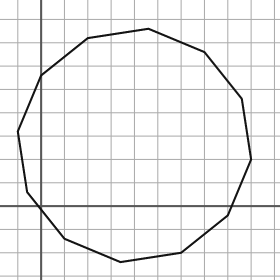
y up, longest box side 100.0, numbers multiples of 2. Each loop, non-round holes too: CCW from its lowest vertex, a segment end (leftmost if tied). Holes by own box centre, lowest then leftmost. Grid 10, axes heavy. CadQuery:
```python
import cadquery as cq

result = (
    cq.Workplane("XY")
    .moveTo(34.0, -24.0)
    .lineTo(60.0, -20.0)
    .lineTo(80.0, -4.0)
    .lineTo(90.0, 20.0)
    .lineTo(86.0, 46.0)
    .lineTo(70.0, 66.0)
    .lineTo(46.0, 76.0)
    .lineTo(20.0, 72.0)
    .lineTo(0.0, 56.0)
    .lineTo(-10.0, 32.0)
    .lineTo(-6.0, 6.0)
    .lineTo(10.0, -14.0)
    .close()
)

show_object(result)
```